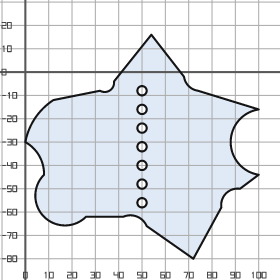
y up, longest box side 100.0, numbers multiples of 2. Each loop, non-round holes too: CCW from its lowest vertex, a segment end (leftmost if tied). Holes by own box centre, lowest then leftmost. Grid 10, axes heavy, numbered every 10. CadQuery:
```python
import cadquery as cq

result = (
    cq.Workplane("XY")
    .moveTo(72.0, -80.0)
    .lineTo(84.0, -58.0)
    .threePointArc((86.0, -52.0), (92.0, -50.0))
    .lineTo(100.0, -44.0)
    .threePointArc((88.0, -30.0), (100.0, -16.0))
    .lineTo(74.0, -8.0)
    .threePointArc((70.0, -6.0), (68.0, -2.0))
    .lineTo(54.0, 16.0)
    .lineTo(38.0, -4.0)
    .threePointArc((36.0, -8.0), (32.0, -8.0))
    .lineTo(12.0, -12.0)
    .threePointArc((4.0, -20.0), (0.0, -30.0))
    .threePointArc((6.0, -36.0), (8.0, -44.0))
    .threePointArc((8.0, -62.0), (26.0, -62.0))
    .lineTo(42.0, -62.0)
    .threePointArc((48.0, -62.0), (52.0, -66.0))
    .close()
    .moveTo(50.0, -56.0)
    .circle(2.0)
    .moveTo(50.0, -48.0)
    .circle(2.0)
    .moveTo(50.0, -40.0)
    .circle(2.0)
    .moveTo(50.0, -32.0)
    .circle(2.0)
    .moveTo(50.0, -24.0)
    .circle(2.0)
    .moveTo(50.0, -16.0)
    .circle(2.0)
    .moveTo(50.0, -8.0)
    .circle(2.0)
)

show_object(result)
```